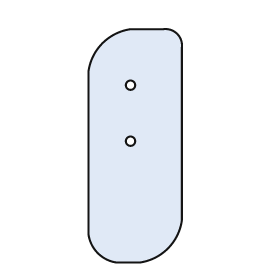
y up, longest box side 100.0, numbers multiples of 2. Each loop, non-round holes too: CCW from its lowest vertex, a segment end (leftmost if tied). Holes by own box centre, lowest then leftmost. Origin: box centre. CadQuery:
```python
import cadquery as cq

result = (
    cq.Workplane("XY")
    .moveTo(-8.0, -50.0)
    .lineTo(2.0, -50.0)
    .threePointArc((14.0, -44.0), (20.0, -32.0))
    .lineTo(20.0, 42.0)
    .threePointArc((18.0, 48.0), (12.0, 50.0))
    .lineTo(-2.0, 50.0)
    .threePointArc((-14.0, 44.0), (-20.0, 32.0))
    .lineTo(-20.0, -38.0)
    .threePointArc((-16.0, -46.0), (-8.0, -50.0))
    .close()
    .moveTo(-2.0, 2.0)
    .circle(2.0)
    .moveTo(-2.0, 26.0)
    .circle(2.0)
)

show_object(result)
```